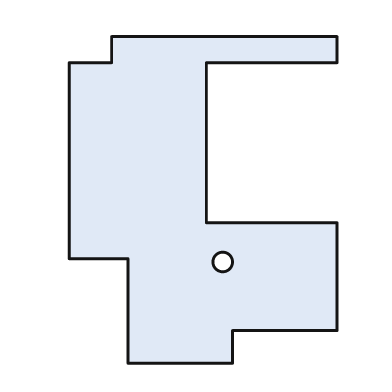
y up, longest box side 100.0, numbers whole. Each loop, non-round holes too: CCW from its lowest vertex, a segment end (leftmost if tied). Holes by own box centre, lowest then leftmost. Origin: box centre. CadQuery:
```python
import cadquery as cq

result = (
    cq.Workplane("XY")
    .moveTo(-23.0, -50.0)
    .lineTo(9.0, -50.0)
    .lineTo(9.0, -40.0)
    .lineTo(41.0, -40.0)
    .lineTo(41.0, -7.0)
    .lineTo(1.0, -7.0)
    .lineTo(1.0, 42.0)
    .lineTo(41.0, 42.0)
    .lineTo(41.0, 50.0)
    .lineTo(-28.0, 50.0)
    .lineTo(-28.0, 42.0)
    .lineTo(-41.0, 42.0)
    .lineTo(-41.0, -18.0)
    .lineTo(-23.0, -18.0)
    .close()
    .moveTo(6.0, -19.0)
    .circle(3.0)
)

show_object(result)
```